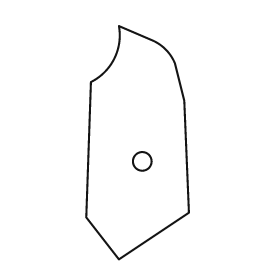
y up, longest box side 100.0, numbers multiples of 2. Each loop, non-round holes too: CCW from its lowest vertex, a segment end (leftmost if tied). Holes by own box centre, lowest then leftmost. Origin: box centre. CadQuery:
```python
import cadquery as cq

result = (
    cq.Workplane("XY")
    .moveTo(-8.0, -50.0)
    .lineTo(22.0, -30.0)
    .lineTo(20.0, 18.0)
    .lineTo(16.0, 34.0)
    .threePointArc((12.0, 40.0), (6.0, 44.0))
    .lineTo(-8.0, 50.0)
    .threePointArc((-10.0, 36.0), (-20.0, 26.0))
    .lineTo(-22.0, -32.0)
    .close()
    .moveTo(2.0, -8.0)
    .circle(4.0)
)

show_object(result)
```